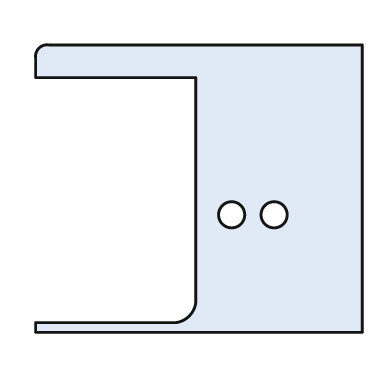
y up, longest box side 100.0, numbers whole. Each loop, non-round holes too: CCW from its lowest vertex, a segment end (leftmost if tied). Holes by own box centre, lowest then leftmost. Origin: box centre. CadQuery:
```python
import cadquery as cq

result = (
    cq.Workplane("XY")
    .moveTo(-50.0, -44.0)
    .lineTo(50.0, -44.0)
    .lineTo(50.0, 44.0)
    .lineTo(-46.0, 44.0)
    .threePointArc((-49.0, 43.0), (-50.0, 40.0))
    .lineTo(-50.0, 34.0)
    .lineTo(-1.0, 34.0)
    .lineTo(-1.0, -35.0)
    .threePointArc((-3.0, -39.0), (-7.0, -41.0))
    .lineTo(-50.0, -41.0)
    .close()
    .moveTo(10.0, -8.0)
    .circle(4.0)
    .moveTo(23.0, -8.0)
    .circle(4.0)
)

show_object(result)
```